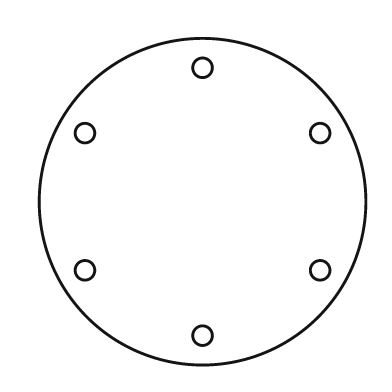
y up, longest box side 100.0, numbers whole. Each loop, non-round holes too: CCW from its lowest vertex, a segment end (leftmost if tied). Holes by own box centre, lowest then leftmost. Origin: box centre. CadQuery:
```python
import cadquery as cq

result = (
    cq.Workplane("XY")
    .moveTo(0.0, 0.0)
    .circle(50.0)
    .moveTo(0.0, -41.0)
    .circle(3.0)
    .moveTo(-36.0, -21.0)
    .circle(3.0)
    .moveTo(36.0, -21.0)
    .circle(3.0)
    .moveTo(-36.0, 21.0)
    .circle(3.0)
    .moveTo(36.0, 21.0)
    .circle(3.0)
    .moveTo(0.0, 41.0)
    .circle(3.0)
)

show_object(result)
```